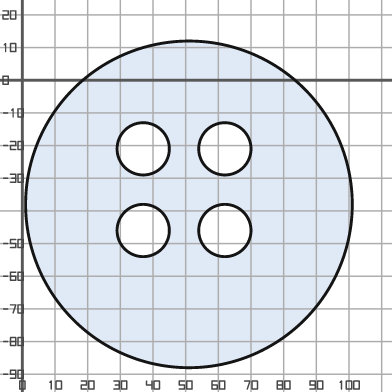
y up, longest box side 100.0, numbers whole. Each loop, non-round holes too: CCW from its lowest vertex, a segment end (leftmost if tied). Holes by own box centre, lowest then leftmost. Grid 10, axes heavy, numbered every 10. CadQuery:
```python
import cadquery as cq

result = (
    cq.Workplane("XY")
    .moveTo(51.0, -38.0)
    .circle(50.0)
    .moveTo(37.0, -46.0)
    .circle(8.0)
    .moveTo(62.0, -46.0)
    .circle(8.0)
    .moveTo(37.0, -21.0)
    .circle(8.0)
    .moveTo(62.0, -21.0)
    .circle(8.0)
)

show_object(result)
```